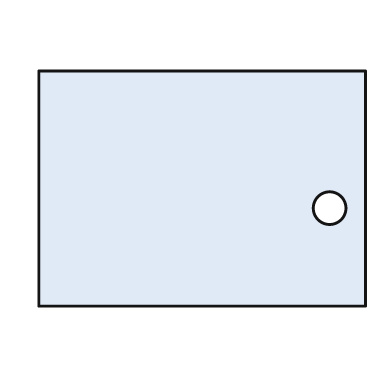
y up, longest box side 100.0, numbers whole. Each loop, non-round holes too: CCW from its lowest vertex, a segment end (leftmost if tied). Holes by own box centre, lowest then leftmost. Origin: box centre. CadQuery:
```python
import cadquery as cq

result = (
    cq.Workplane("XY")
    .moveTo(-50.0, -36.0)
    .lineTo(50.0, -36.0)
    .lineTo(50.0, 36.0)
    .lineTo(-50.0, 36.0)
    .close()
    .moveTo(39.0, -6.0)
    .circle(5.0)
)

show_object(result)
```